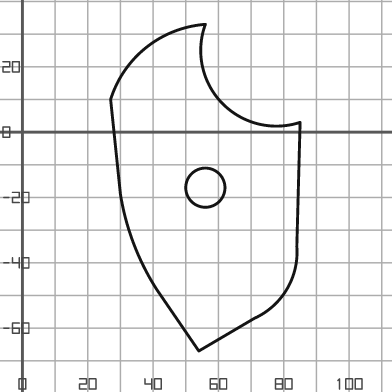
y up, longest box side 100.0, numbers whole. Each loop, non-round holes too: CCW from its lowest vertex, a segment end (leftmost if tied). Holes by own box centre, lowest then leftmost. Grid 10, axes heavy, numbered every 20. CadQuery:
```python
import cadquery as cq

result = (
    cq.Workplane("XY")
    .moveTo(54.0, -67.0)
    .lineTo(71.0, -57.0)
    .threePointArc((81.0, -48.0), (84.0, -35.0))
    .lineTo(85.0, 3.0)
    .threePointArc((61.0, 9.0), (56.0, 33.0))
    .threePointArc((38.0, 26.0), (27.0, 10.0))
    .lineTo(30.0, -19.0)
    .threePointArc((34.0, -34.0), (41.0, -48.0))
    .close()
    .moveTo(56.0, -17.0)
    .circle(6.0)
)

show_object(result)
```